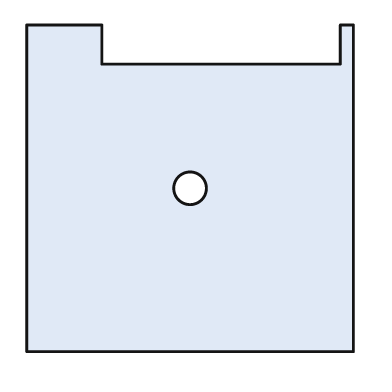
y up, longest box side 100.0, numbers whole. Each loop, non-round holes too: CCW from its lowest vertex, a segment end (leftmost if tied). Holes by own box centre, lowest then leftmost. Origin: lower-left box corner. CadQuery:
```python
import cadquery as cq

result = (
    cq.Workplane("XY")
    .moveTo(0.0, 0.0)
    .lineTo(100.0, 0.0)
    .lineTo(100.0, 100.0)
    .lineTo(96.0, 100.0)
    .lineTo(96.0, 88.0)
    .lineTo(23.0, 88.0)
    .lineTo(23.0, 100.0)
    .lineTo(0.0, 100.0)
    .close()
    .moveTo(50.0, 50.0)
    .circle(5.0)
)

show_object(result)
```